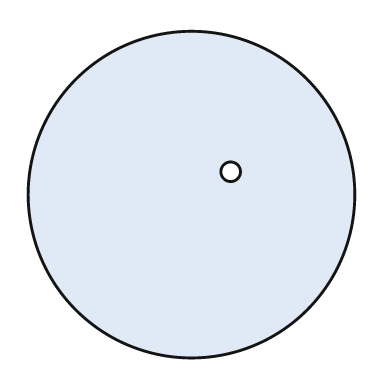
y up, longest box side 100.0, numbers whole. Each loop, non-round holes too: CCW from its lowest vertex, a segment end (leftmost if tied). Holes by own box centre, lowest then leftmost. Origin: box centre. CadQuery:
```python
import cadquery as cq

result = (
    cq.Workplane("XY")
    .moveTo(0.0, 0.0)
    .circle(50.0)
    .moveTo(12.0, 7.0)
    .circle(3.0)
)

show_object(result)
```